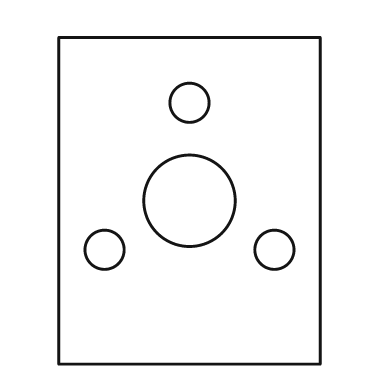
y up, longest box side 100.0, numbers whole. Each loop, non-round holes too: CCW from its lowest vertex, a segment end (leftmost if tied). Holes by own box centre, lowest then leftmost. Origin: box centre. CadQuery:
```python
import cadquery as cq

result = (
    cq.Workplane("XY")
    .moveTo(-40.0, -50.0)
    .lineTo(40.0, -50.0)
    .lineTo(40.0, 50.0)
    .lineTo(-40.0, 50.0)
    .close()
    .moveTo(-26.0, -15.0)
    .circle(6.0)
    .moveTo(26.0, -15.0)
    .circle(6.0)
    .moveTo(0.0, 0.0)
    .circle(14.0)
    .moveTo(0.0, 30.0)
    .circle(6.0)
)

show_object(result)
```